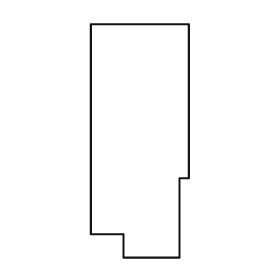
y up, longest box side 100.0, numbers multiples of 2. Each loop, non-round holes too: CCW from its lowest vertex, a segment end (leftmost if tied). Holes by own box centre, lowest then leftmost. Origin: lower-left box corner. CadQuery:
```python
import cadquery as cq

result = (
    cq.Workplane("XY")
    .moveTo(14.0, 0.0)
    .lineTo(38.0, 0.0)
    .lineTo(38.0, 34.0)
    .lineTo(42.0, 34.0)
    .lineTo(42.0, 100.0)
    .lineTo(0.0, 100.0)
    .lineTo(0.0, 10.0)
    .lineTo(14.0, 10.0)
    .close()
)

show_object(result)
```